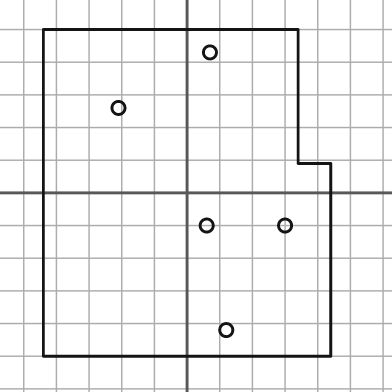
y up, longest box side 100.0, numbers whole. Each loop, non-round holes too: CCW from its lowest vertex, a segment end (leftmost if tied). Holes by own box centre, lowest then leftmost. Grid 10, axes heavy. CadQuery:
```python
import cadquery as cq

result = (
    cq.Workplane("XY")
    .moveTo(-44.0, -50.0)
    .lineTo(44.0, -50.0)
    .lineTo(44.0, 9.0)
    .lineTo(34.0, 9.0)
    .lineTo(34.0, 50.0)
    .lineTo(-44.0, 50.0)
    .close()
    .moveTo(12.0, -42.0)
    .circle(2.0)
    .moveTo(6.0, -10.0)
    .circle(2.0)
    .moveTo(30.0, -10.0)
    .circle(2.0)
    .moveTo(-21.0, 26.0)
    .circle(2.0)
    .moveTo(7.0, 43.0)
    .circle(2.0)
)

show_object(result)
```